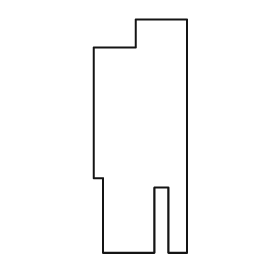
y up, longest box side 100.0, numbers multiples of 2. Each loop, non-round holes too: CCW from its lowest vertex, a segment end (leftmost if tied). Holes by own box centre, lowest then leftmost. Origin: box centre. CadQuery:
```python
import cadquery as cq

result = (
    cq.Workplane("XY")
    .moveTo(-16.0, -50.0)
    .lineTo(6.0, -50.0)
    .lineTo(6.0, -22.0)
    .lineTo(12.0, -22.0)
    .lineTo(12.0, -50.0)
    .lineTo(20.0, -50.0)
    .lineTo(20.0, 50.0)
    .lineTo(-2.0, 50.0)
    .lineTo(-2.0, 38.0)
    .lineTo(-20.0, 38.0)
    .lineTo(-20.0, -18.0)
    .lineTo(-16.0, -18.0)
    .close()
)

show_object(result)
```